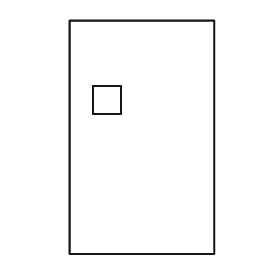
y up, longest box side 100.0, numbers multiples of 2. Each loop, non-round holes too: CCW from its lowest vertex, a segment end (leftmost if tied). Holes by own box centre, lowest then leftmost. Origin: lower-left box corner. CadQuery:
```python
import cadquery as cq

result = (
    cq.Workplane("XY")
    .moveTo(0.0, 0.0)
    .lineTo(62.0, 0.0)
    .lineTo(62.0, 100.0)
    .lineTo(0.0, 100.0)
    .close()
    .moveTo(10.0, 60.0)
    .lineTo(22.0, 60.0)
    .lineTo(22.0, 72.0)
    .lineTo(10.0, 72.0)
    .close()
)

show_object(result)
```